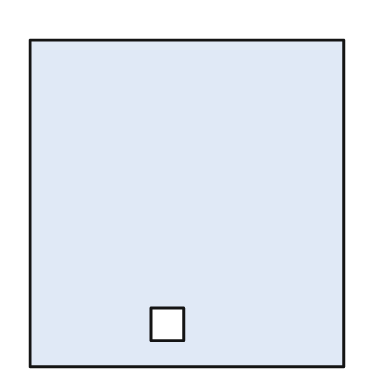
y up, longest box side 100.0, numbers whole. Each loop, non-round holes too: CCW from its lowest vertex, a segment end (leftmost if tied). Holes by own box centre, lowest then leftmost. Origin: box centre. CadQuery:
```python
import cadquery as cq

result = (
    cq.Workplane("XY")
    .moveTo(-48.0, -50.0)
    .lineTo(48.0, -50.0)
    .lineTo(48.0, 50.0)
    .lineTo(-48.0, 50.0)
    .close()
    .moveTo(-11.0, -42.0)
    .lineTo(-1.0, -42.0)
    .lineTo(-1.0, -32.0)
    .lineTo(-11.0, -32.0)
    .close()
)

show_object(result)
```